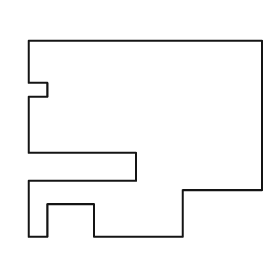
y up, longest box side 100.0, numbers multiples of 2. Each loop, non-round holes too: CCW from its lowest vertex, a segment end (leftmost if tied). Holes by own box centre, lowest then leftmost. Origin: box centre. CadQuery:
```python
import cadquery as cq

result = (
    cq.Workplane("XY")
    .moveTo(-50.0, -42.0)
    .lineTo(-42.0, -42.0)
    .lineTo(-42.0, -28.0)
    .lineTo(-22.0, -28.0)
    .lineTo(-22.0, -42.0)
    .lineTo(16.0, -42.0)
    .lineTo(16.0, -22.0)
    .lineTo(50.0, -22.0)
    .lineTo(50.0, 42.0)
    .lineTo(-50.0, 42.0)
    .lineTo(-50.0, 24.0)
    .lineTo(-42.0, 24.0)
    .lineTo(-42.0, 18.0)
    .lineTo(-50.0, 18.0)
    .lineTo(-50.0, -6.0)
    .lineTo(-4.0, -6.0)
    .lineTo(-4.0, -18.0)
    .lineTo(-50.0, -18.0)
    .close()
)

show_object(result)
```